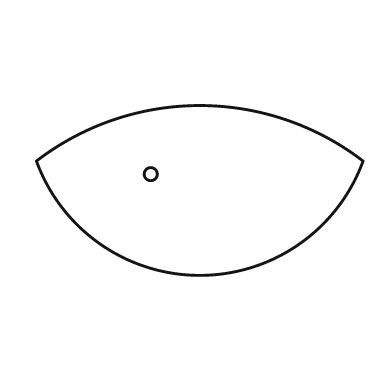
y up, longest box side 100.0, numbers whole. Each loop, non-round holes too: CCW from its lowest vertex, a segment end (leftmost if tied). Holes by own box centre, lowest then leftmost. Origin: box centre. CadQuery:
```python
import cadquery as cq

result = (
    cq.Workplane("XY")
    .moveTo(-50.0, 9.0)
    .threePointArc((0.0, -26.0), (50.0, 9.0))
    .threePointArc((0.0, 26.0), (-50.0, 9.0))
    .close()
    .moveTo(-15.0, 5.0)
    .circle(2.0)
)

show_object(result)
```